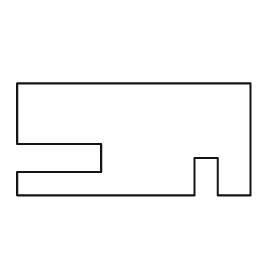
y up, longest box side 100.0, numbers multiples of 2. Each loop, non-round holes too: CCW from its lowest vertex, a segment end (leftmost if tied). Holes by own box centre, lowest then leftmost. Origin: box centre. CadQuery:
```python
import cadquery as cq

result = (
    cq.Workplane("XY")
    .moveTo(-50.0, -24.0)
    .lineTo(26.0, -24.0)
    .lineTo(26.0, -8.0)
    .lineTo(36.0, -8.0)
    .lineTo(36.0, -24.0)
    .lineTo(50.0, -24.0)
    .lineTo(50.0, 24.0)
    .lineTo(-50.0, 24.0)
    .lineTo(-50.0, -2.0)
    .lineTo(-14.0, -2.0)
    .lineTo(-14.0, -14.0)
    .lineTo(-50.0, -14.0)
    .close()
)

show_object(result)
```